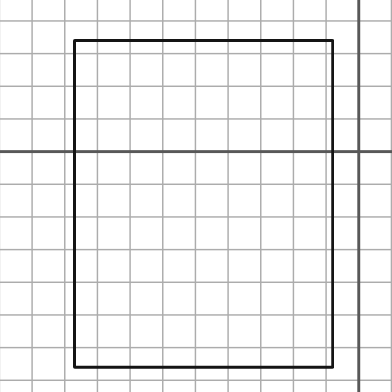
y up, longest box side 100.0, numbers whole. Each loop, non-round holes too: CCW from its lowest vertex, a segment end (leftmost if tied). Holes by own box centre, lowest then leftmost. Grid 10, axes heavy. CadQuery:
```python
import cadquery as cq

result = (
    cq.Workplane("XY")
    .moveTo(-87.0, -66.0)
    .lineTo(-8.0, -66.0)
    .lineTo(-8.0, 34.0)
    .lineTo(-87.0, 34.0)
    .close()
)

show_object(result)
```